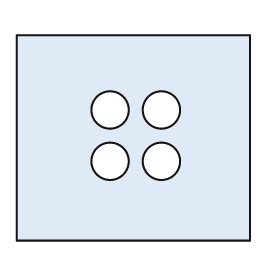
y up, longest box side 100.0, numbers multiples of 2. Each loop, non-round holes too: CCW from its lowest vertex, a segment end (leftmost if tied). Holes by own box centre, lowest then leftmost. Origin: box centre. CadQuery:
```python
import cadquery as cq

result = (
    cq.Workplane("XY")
    .moveTo(-50.0, -44.0)
    .lineTo(50.0, -44.0)
    .lineTo(50.0, 44.0)
    .lineTo(-50.0, 44.0)
    .close()
    .moveTo(-10.0, -10.0)
    .circle(8.0)
    .moveTo(12.0, -10.0)
    .circle(8.0)
    .moveTo(-10.0, 12.0)
    .circle(8.0)
    .moveTo(12.0, 12.0)
    .circle(8.0)
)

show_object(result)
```